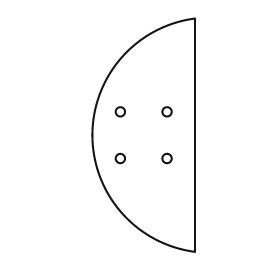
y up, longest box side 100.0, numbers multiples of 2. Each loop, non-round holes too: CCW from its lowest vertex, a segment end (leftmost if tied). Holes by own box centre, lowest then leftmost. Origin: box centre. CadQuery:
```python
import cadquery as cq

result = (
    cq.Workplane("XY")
    .moveTo(22.0, -50.0)
    .lineTo(22.0, 50.0)
    .threePointArc((-22.0, 0.0), (22.0, -50.0))
    .close()
    .moveTo(-10.0, -10.0)
    .circle(2.0)
    .moveTo(10.0, -10.0)
    .circle(2.0)
    .moveTo(-10.0, 10.0)
    .circle(2.0)
    .moveTo(10.0, 10.0)
    .circle(2.0)
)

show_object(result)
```